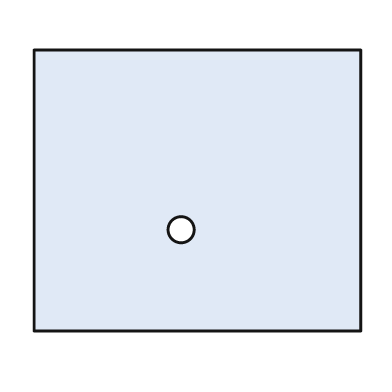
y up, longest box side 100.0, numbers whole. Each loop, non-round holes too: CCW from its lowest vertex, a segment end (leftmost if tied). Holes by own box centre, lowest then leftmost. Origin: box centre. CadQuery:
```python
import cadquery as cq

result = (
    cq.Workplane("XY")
    .moveTo(-50.0, -43.0)
    .lineTo(50.0, -43.0)
    .lineTo(50.0, 43.0)
    .lineTo(-50.0, 43.0)
    .close()
    .moveTo(-5.0, -12.0)
    .circle(4.0)
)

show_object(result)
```